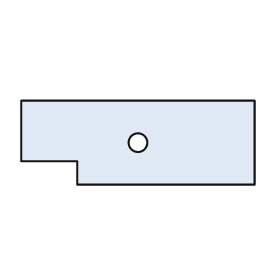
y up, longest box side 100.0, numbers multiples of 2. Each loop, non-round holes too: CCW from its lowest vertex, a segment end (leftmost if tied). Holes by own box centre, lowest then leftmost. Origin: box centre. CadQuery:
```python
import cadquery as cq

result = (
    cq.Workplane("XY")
    .moveTo(-26.0, -18.0)
    .lineTo(50.0, -18.0)
    .lineTo(50.0, 18.0)
    .lineTo(-50.0, 18.0)
    .lineTo(-50.0, -8.0)
    .lineTo(-26.0, -8.0)
    .close()
    .moveTo(0.0, 0.0)
    .circle(4.0)
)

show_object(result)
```